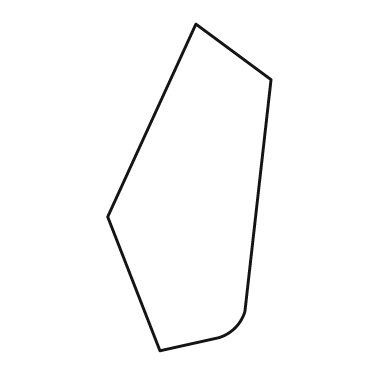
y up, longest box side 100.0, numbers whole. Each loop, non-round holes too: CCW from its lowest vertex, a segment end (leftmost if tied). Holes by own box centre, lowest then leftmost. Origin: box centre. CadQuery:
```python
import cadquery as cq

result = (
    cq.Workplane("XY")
    .moveTo(-9.0, -50.0)
    .lineTo(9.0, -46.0)
    .threePointArc((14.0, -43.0), (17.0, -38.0))
    .lineTo(25.0, 33.0)
    .lineTo(2.0, 50.0)
    .lineTo(-25.0, -9.0)
    .close()
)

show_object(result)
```